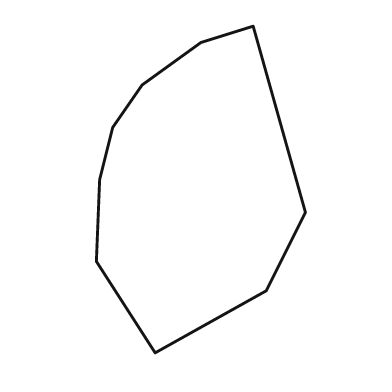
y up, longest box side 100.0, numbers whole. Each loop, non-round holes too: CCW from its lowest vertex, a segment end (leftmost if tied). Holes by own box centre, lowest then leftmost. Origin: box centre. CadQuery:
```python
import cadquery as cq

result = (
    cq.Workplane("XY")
    .moveTo(-14.0, -50.0)
    .lineTo(20.0, -31.0)
    .lineTo(32.0, -7.0)
    .lineTo(16.0, 50.0)
    .lineTo(0.0, 45.0)
    .lineTo(-18.0, 32.0)
    .lineTo(-27.0, 19.0)
    .lineTo(-31.0, 3.0)
    .lineTo(-32.0, -22.0)
    .close()
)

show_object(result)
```